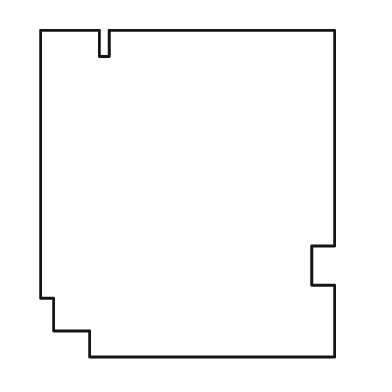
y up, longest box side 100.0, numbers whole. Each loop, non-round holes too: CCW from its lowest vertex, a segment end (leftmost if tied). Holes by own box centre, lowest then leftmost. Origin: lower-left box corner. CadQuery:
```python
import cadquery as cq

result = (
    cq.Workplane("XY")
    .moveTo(15.0, 0.0)
    .lineTo(90.0, 0.0)
    .lineTo(90.0, 22.0)
    .lineTo(83.0, 22.0)
    .lineTo(83.0, 34.0)
    .lineTo(90.0, 34.0)
    .lineTo(90.0, 100.0)
    .lineTo(21.0, 100.0)
    .lineTo(21.0, 92.0)
    .lineTo(18.0, 92.0)
    .lineTo(18.0, 100.0)
    .lineTo(0.0, 100.0)
    .lineTo(0.0, 18.0)
    .lineTo(4.0, 18.0)
    .lineTo(4.0, 8.0)
    .lineTo(15.0, 8.0)
    .close()
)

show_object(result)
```